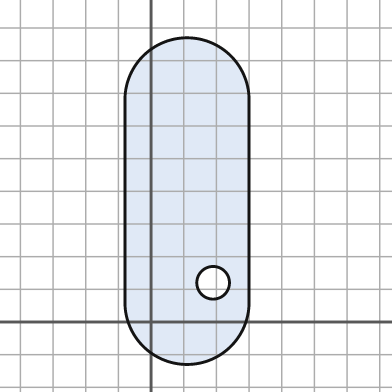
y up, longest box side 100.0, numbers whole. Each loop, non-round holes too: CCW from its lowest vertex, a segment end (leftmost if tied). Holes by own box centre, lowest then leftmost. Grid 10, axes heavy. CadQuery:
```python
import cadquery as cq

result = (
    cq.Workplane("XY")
    .moveTo(-8.0, 6.0)
    .threePointArc((11.0, -13.0), (30.0, 6.0))
    .lineTo(30.0, 68.0)
    .threePointArc((11.0, 87.0), (-8.0, 68.0))
    .close()
    .moveTo(19.0, 12.0)
    .circle(5.0)
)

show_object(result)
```